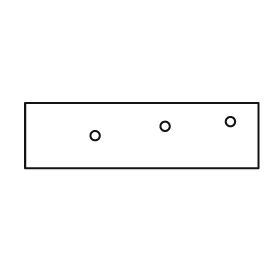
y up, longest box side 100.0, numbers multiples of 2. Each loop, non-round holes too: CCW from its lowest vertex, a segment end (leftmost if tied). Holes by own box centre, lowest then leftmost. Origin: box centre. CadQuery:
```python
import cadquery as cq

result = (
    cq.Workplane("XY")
    .moveTo(-50.0, -14.0)
    .lineTo(50.0, -14.0)
    .lineTo(50.0, 14.0)
    .lineTo(-50.0, 14.0)
    .close()
    .moveTo(-20.0, 0.0)
    .circle(2.0)
    .moveTo(10.0, 4.0)
    .circle(2.0)
    .moveTo(38.0, 6.0)
    .circle(2.0)
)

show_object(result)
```